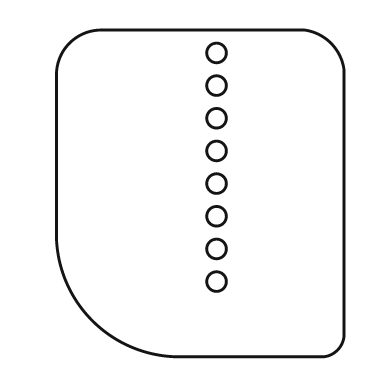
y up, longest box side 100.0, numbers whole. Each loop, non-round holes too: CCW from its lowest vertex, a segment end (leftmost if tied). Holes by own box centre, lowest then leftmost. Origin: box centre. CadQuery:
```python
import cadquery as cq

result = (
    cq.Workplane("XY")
    .moveTo(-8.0, -50.0)
    .lineTo(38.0, -50.0)
    .threePointArc((42.0, -48.0), (44.0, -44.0))
    .lineTo(44.0, 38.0)
    .threePointArc((40.0, 46.0), (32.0, 50.0))
    .lineTo(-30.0, 50.0)
    .threePointArc((-40.0, 46.0), (-44.0, 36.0))
    .lineTo(-44.0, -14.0)
    .threePointArc((-33.0, -39.0), (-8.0, -50.0))
    .close()
    .moveTo(5.0, -27.0)
    .circle(3.0)
    .moveTo(5.0, -17.0)
    .circle(3.0)
    .moveTo(5.0, -7.0)
    .circle(3.0)
    .moveTo(5.0, 3.0)
    .circle(3.0)
    .moveTo(5.0, 13.0)
    .circle(3.0)
    .moveTo(5.0, 23.0)
    .circle(3.0)
    .moveTo(5.0, 33.0)
    .circle(3.0)
    .moveTo(5.0, 43.0)
    .circle(3.0)
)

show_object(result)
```